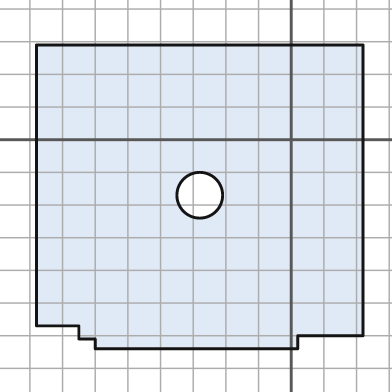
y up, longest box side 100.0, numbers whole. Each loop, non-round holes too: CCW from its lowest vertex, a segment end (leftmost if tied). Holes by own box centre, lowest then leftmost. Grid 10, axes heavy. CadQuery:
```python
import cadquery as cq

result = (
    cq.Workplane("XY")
    .moveTo(-60.0, -64.0)
    .lineTo(2.0, -64.0)
    .lineTo(2.0, -60.0)
    .lineTo(22.0, -60.0)
    .lineTo(22.0, 29.0)
    .lineTo(-78.0, 29.0)
    .lineTo(-78.0, -57.0)
    .lineTo(-65.0, -57.0)
    .lineTo(-65.0, -61.0)
    .lineTo(-60.0, -61.0)
    .close()
    .moveTo(-28.0, -17.0)
    .circle(7.0)
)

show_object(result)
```